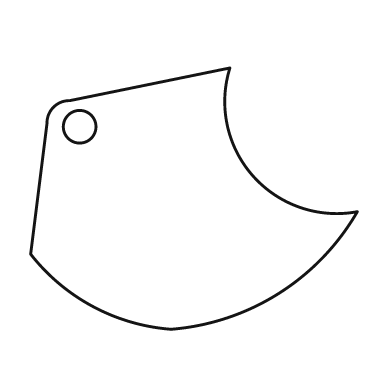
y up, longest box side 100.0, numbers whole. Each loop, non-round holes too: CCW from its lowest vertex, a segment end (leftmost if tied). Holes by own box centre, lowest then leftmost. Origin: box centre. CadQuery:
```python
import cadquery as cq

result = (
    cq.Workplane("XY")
    .moveTo(-7.0, -40.0)
    .threePointArc((26.0, -29.0), (50.0, -4.0))
    .threePointArc((18.0, 7.0), (11.0, 40.0))
    .lineTo(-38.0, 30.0)
    .threePointArc((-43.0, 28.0), (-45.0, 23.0))
    .lineTo(-50.0, -17.0)
    .threePointArc((-31.0, -33.0), (-7.0, -40.0))
    .close()
    .moveTo(-35.0, 22.0)
    .circle(5.0)
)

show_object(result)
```